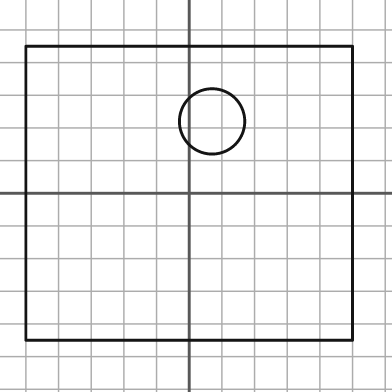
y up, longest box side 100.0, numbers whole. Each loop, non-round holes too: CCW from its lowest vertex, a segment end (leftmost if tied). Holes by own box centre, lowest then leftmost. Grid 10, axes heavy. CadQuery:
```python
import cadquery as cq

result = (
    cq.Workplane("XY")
    .moveTo(-50.0, -45.0)
    .lineTo(50.0, -45.0)
    .lineTo(50.0, 45.0)
    .lineTo(-50.0, 45.0)
    .close()
    .moveTo(7.0, 22.0)
    .circle(10.0)
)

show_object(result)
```